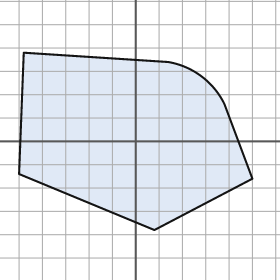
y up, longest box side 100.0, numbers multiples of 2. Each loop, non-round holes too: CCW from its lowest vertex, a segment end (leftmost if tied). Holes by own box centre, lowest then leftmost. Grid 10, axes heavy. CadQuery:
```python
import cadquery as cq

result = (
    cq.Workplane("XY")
    .moveTo(8.0, -38.0)
    .lineTo(50.0, -16.0)
    .lineTo(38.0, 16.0)
    .threePointArc((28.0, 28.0), (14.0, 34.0))
    .lineTo(-48.0, 38.0)
    .lineTo(-50.0, -14.0)
    .close()
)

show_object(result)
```